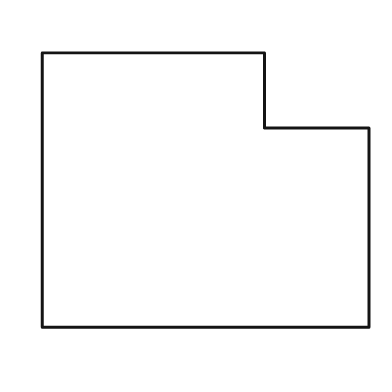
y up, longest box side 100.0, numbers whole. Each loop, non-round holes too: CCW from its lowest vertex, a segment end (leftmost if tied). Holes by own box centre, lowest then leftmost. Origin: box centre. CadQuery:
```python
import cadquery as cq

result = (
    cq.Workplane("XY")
    .moveTo(-50.0, -42.0)
    .lineTo(50.0, -42.0)
    .lineTo(50.0, 19.0)
    .lineTo(18.0, 19.0)
    .lineTo(18.0, 42.0)
    .lineTo(-50.0, 42.0)
    .close()
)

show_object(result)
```